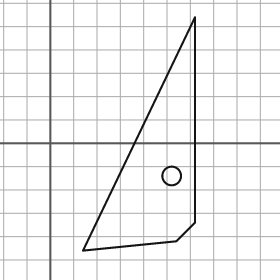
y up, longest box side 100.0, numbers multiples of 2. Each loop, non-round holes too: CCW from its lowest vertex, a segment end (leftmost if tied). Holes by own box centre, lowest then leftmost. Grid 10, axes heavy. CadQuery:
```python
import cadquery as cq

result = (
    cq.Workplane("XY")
    .moveTo(14.0, -46.0)
    .lineTo(54.0, -42.0)
    .lineTo(62.0, -34.0)
    .lineTo(62.0, 54.0)
    .close()
    .moveTo(52.0, -14.0)
    .circle(4.0)
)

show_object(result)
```